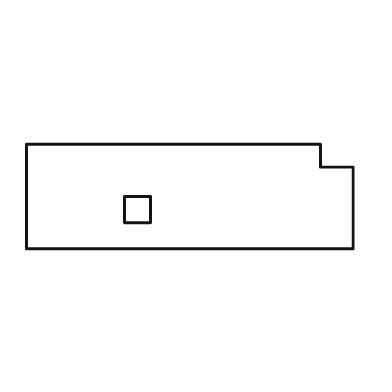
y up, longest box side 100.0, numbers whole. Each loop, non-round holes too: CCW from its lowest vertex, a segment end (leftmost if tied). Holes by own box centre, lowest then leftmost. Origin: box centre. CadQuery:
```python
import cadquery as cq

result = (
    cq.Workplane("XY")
    .moveTo(-50.0, -16.0)
    .lineTo(50.0, -16.0)
    .lineTo(50.0, 9.0)
    .lineTo(40.0, 9.0)
    .lineTo(40.0, 16.0)
    .lineTo(-50.0, 16.0)
    .close()
    .moveTo(-20.0, -8.0)
    .lineTo(-12.0, -8.0)
    .lineTo(-12.0, 0.0)
    .lineTo(-20.0, 0.0)
    .close()
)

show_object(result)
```